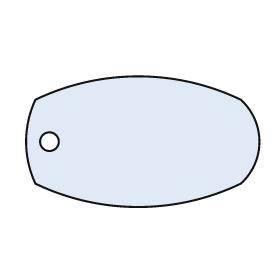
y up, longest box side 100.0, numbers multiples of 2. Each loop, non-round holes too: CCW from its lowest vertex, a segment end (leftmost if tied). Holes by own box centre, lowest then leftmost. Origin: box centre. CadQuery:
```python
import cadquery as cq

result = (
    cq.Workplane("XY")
    .moveTo(-46.0, -18.0)
    .threePointArc((-2.0, -28.0), (42.0, -18.0))
    .threePointArc((50.0, 0.0), (42.0, 18.0))
    .threePointArc((-2.0, 28.0), (-46.0, 18.0))
    .threePointArc((-50.0, 0.0), (-46.0, -18.0))
    .close()
    .moveTo(-40.0, 0.0)
    .circle(4.0)
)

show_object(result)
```